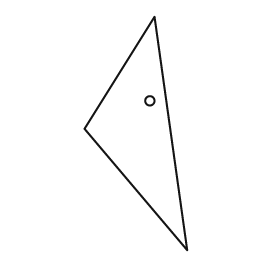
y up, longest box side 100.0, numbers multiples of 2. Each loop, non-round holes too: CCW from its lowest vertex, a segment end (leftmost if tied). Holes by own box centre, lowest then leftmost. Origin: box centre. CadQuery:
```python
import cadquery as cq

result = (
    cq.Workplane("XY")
    .moveTo(22.0, -50.0)
    .lineTo(8.0, 50.0)
    .lineTo(-22.0, 2.0)
    .close()
    .moveTo(6.0, 14.0)
    .circle(2.0)
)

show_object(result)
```